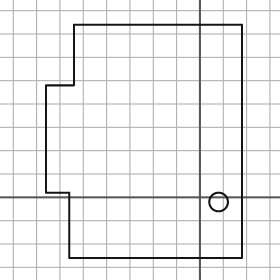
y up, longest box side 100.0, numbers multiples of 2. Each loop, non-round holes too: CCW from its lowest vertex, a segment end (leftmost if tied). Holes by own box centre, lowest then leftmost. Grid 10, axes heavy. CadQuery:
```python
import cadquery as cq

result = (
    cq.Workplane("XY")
    .moveTo(-56.0, -26.0)
    .lineTo(18.0, -26.0)
    .lineTo(18.0, 74.0)
    .lineTo(-54.0, 74.0)
    .lineTo(-54.0, 48.0)
    .lineTo(-66.0, 48.0)
    .lineTo(-66.0, 2.0)
    .lineTo(-56.0, 2.0)
    .close()
    .moveTo(8.0, -2.0)
    .circle(4.0)
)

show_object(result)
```